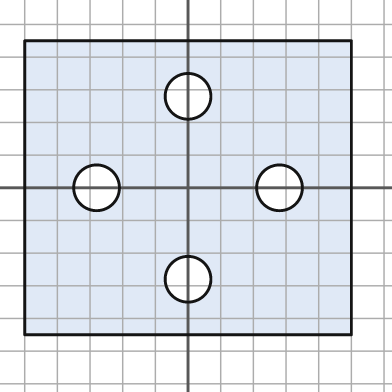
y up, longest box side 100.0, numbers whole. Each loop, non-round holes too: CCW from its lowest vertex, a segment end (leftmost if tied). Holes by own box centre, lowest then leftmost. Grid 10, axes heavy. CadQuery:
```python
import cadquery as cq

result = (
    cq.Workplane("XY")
    .moveTo(-50.0, -45.0)
    .lineTo(50.0, -45.0)
    .lineTo(50.0, 45.0)
    .lineTo(-50.0, 45.0)
    .close()
    .moveTo(0.0, -28.0)
    .circle(7.0)
    .moveTo(-28.0, 0.0)
    .circle(7.0)
    .moveTo(28.0, 0.0)
    .circle(7.0)
    .moveTo(0.0, 28.0)
    .circle(7.0)
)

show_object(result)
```